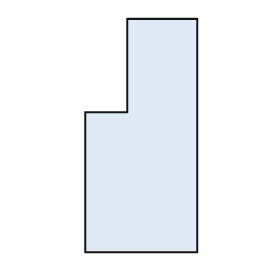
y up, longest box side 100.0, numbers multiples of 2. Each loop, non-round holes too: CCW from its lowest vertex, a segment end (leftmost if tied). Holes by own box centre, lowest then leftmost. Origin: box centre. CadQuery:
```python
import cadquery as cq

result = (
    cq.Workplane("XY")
    .moveTo(-24.0, -50.0)
    .lineTo(24.0, -50.0)
    .lineTo(24.0, 50.0)
    .lineTo(-6.0, 50.0)
    .lineTo(-6.0, 10.0)
    .lineTo(-24.0, 10.0)
    .close()
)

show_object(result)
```